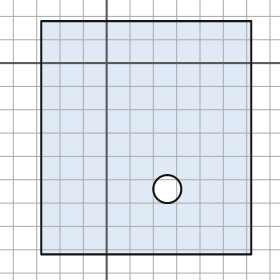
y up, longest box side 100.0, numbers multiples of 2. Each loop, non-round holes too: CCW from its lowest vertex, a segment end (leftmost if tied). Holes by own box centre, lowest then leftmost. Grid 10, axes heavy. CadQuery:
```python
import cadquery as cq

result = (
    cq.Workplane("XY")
    .moveTo(-28.0, -82.0)
    .lineTo(62.0, -82.0)
    .lineTo(62.0, 18.0)
    .lineTo(-28.0, 18.0)
    .close()
    .moveTo(26.0, -54.0)
    .circle(6.0)
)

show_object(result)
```